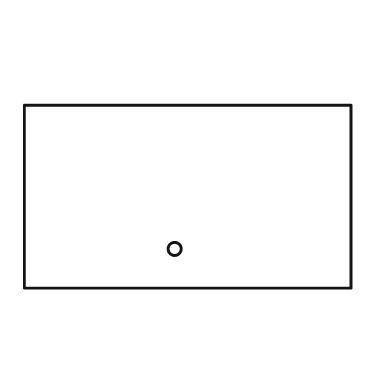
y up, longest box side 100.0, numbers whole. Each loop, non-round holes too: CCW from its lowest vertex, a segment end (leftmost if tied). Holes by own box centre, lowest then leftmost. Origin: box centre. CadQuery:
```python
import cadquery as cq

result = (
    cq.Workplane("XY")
    .moveTo(-50.0, -28.0)
    .lineTo(50.0, -28.0)
    .lineTo(50.0, 28.0)
    .lineTo(-50.0, 28.0)
    .close()
    .moveTo(-4.0, -16.0)
    .circle(2.0)
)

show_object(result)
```